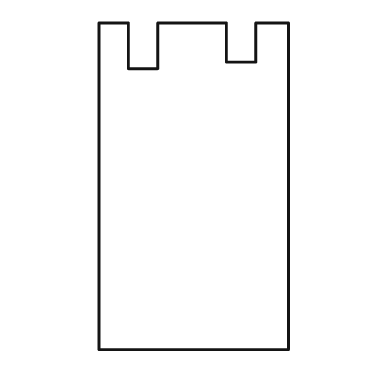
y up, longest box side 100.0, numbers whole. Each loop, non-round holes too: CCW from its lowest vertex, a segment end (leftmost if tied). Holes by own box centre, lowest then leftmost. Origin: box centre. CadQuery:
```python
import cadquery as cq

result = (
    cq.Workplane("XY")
    .moveTo(-29.0, -50.0)
    .lineTo(29.0, -50.0)
    .lineTo(29.0, 50.0)
    .lineTo(19.0, 50.0)
    .lineTo(19.0, 38.0)
    .lineTo(10.0, 38.0)
    .lineTo(10.0, 50.0)
    .lineTo(-11.0, 50.0)
    .lineTo(-11.0, 36.0)
    .lineTo(-20.0, 36.0)
    .lineTo(-20.0, 50.0)
    .lineTo(-29.0, 50.0)
    .close()
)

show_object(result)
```